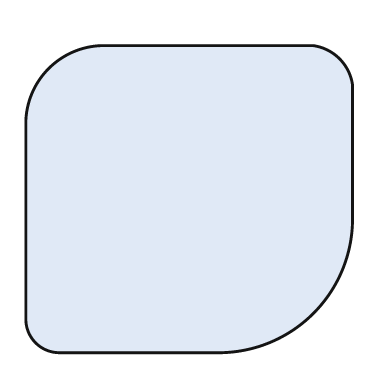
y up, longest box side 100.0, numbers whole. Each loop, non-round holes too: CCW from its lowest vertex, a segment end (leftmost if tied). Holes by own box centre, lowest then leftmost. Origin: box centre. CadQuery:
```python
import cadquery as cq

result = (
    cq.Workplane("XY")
    .moveTo(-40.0, -47.0)
    .lineTo(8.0, -47.0)
    .threePointArc((38.0, -35.0), (50.0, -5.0))
    .lineTo(50.0, 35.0)
    .threePointArc((46.0, 43.0), (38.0, 47.0))
    .lineTo(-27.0, 47.0)
    .threePointArc((-43.0, 40.0), (-50.0, 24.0))
    .lineTo(-50.0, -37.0)
    .threePointArc((-47.0, -44.0), (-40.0, -47.0))
    .close()
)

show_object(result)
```